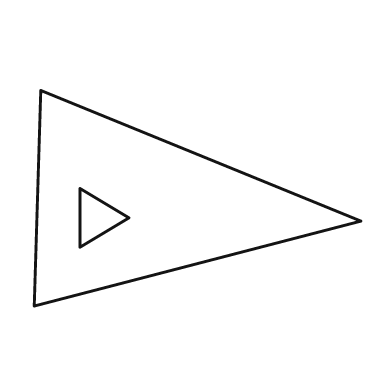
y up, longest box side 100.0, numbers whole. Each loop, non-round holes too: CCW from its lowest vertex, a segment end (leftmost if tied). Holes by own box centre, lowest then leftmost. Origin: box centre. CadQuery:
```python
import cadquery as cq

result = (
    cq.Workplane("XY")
    .moveTo(-50.0, -33.0)
    .lineTo(50.0, -7.0)
    .lineTo(-48.0, 33.0)
    .close()
    .moveTo(-36.0, -15.0)
    .lineTo(-21.0, -6.0)
    .lineTo(-36.0, 3.0)
    .close()
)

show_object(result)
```